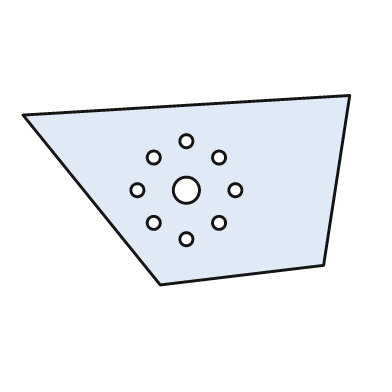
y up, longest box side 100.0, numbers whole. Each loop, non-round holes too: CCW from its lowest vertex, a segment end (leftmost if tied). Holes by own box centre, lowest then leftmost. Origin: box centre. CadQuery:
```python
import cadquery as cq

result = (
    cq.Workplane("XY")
    .moveTo(-8.0, -29.0)
    .lineTo(42.0, -23.0)
    .lineTo(50.0, 29.0)
    .lineTo(-50.0, 23.0)
    .close()
    .moveTo(0.0, -15.0)
    .circle(2.0)
    .moveTo(-10.0, -10.0)
    .circle(2.0)
    .moveTo(10.0, -10.0)
    .circle(2.0)
    .moveTo(-15.0, 0.0)
    .circle(2.0)
    .moveTo(0.0, 0.0)
    .circle(4.0)
    .moveTo(15.0, 0.0)
    .circle(2.0)
    .moveTo(-10.0, 10.0)
    .circle(2.0)
    .moveTo(10.0, 10.0)
    .circle(2.0)
    .moveTo(0.0, 15.0)
    .circle(2.0)
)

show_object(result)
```